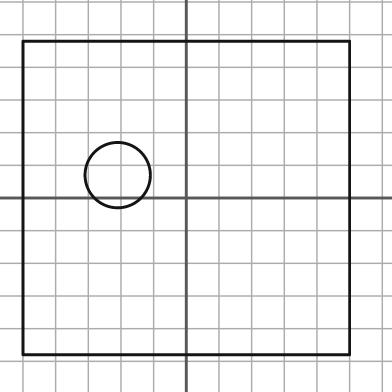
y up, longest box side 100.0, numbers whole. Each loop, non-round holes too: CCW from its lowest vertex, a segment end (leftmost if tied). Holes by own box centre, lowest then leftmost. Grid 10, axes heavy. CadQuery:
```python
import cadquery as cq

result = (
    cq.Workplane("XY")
    .moveTo(-50.0, -48.0)
    .lineTo(50.0, -48.0)
    .lineTo(50.0, 48.0)
    .lineTo(-50.0, 48.0)
    .close()
    .moveTo(-21.0, 7.0)
    .circle(10.0)
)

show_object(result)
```